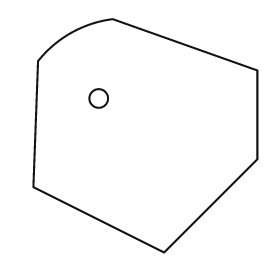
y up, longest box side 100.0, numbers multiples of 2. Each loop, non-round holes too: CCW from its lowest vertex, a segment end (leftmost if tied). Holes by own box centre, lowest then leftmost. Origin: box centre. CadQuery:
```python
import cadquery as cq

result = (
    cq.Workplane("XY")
    .moveTo(8.0, -50.0)
    .lineTo(48.0, -10.0)
    .lineTo(48.0, 28.0)
    .lineTo(-14.0, 50.0)
    .threePointArc((-32.0, 44.0), (-46.0, 32.0))
    .lineTo(-48.0, -22.0)
    .close()
    .moveTo(-20.0, 16.0)
    .circle(4.0)
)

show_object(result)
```